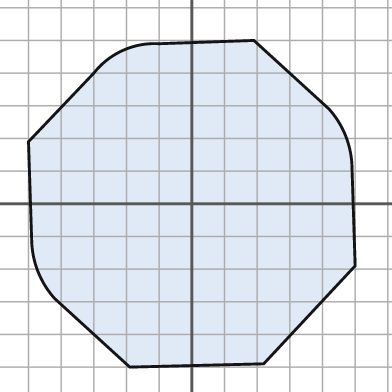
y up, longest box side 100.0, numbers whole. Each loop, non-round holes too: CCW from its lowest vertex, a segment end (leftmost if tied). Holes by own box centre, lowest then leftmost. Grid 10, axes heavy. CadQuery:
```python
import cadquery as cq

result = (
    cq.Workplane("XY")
    .moveTo(-19.0, -50.0)
    .lineTo(22.0, -49.0)
    .lineTo(50.0, -19.0)
    .lineTo(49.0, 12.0)
    .threePointArc((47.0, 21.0), (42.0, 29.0))
    .lineTo(19.0, 50.0)
    .lineTo(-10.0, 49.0)
    .threePointArc((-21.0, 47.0), (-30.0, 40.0))
    .lineTo(-50.0, 19.0)
    .lineTo(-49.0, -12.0)
    .threePointArc((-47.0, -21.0), (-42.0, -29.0))
    .close()
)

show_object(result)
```